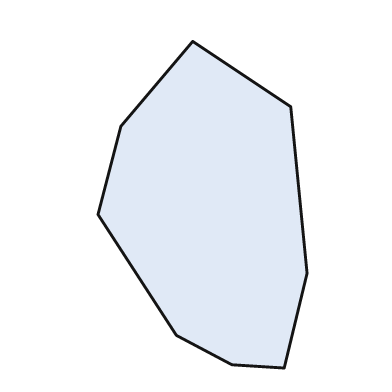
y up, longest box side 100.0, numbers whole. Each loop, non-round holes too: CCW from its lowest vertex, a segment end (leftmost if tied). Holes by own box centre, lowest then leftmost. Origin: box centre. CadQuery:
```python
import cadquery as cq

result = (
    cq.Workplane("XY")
    .moveTo(25.0, -50.0)
    .lineTo(32.0, -21.0)
    .lineTo(27.0, 30.0)
    .lineTo(-3.0, 50.0)
    .lineTo(-25.0, 24.0)
    .lineTo(-32.0, -3.0)
    .lineTo(-8.0, -40.0)
    .lineTo(9.0, -49.0)
    .close()
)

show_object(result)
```